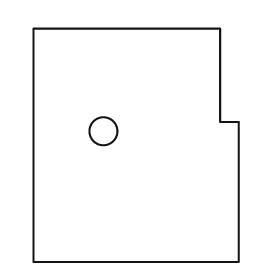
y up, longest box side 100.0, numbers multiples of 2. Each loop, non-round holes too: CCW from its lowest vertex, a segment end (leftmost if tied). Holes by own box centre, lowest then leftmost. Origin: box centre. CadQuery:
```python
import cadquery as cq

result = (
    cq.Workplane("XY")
    .moveTo(-44.0, -50.0)
    .lineTo(44.0, -50.0)
    .lineTo(44.0, 10.0)
    .lineTo(36.0, 10.0)
    .lineTo(36.0, 50.0)
    .lineTo(-44.0, 50.0)
    .close()
    .moveTo(-14.0, 6.0)
    .circle(6.0)
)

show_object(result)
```